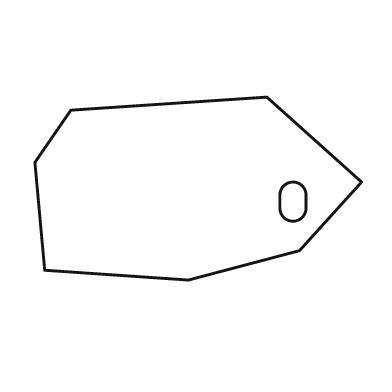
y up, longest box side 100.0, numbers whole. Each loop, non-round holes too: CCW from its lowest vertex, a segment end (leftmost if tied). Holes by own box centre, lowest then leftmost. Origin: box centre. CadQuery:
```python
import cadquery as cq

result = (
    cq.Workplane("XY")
    .moveTo(-3.0, -28.0)
    .lineTo(31.0, -19.0)
    .lineTo(50.0, 2.0)
    .lineTo(21.0, 28.0)
    .lineTo(-39.0, 24.0)
    .lineTo(-50.0, 8.0)
    .lineTo(-47.0, -25.0)
    .close()
    .moveTo(25.0, -6.0)
    .threePointArc((29.0, -10.0), (33.0, -6.0))
    .lineTo(33.0, -2.0)
    .threePointArc((29.0, 2.0), (25.0, -2.0))
    .close()
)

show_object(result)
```